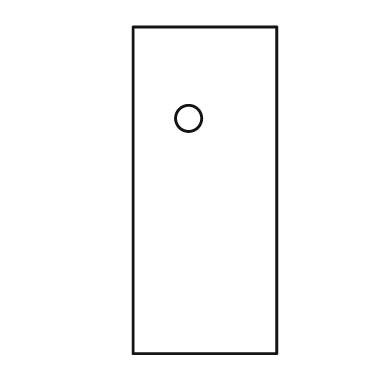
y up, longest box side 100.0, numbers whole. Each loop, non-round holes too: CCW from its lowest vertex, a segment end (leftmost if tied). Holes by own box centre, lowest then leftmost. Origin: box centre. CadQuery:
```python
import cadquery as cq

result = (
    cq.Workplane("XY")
    .moveTo(-22.0, -50.0)
    .lineTo(22.0, -50.0)
    .lineTo(22.0, 50.0)
    .lineTo(-22.0, 50.0)
    .close()
    .moveTo(-5.0, 22.0)
    .circle(4.0)
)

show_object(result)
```